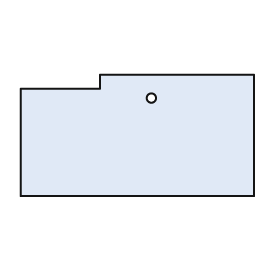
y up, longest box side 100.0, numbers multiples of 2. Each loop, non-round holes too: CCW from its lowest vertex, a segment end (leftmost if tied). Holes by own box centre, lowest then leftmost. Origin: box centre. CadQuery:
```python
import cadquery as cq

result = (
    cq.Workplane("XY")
    .moveTo(-50.0, -26.0)
    .lineTo(50.0, -26.0)
    .lineTo(50.0, 26.0)
    .lineTo(-16.0, 26.0)
    .lineTo(-16.0, 20.0)
    .lineTo(-50.0, 20.0)
    .close()
    .moveTo(6.0, 16.0)
    .circle(2.0)
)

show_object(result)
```